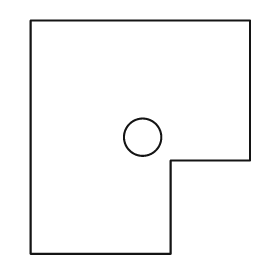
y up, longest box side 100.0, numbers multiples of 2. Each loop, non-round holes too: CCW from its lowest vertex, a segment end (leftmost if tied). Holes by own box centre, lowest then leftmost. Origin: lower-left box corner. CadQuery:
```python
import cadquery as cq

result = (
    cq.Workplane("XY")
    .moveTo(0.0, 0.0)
    .lineTo(60.0, 0.0)
    .lineTo(60.0, 40.0)
    .lineTo(94.0, 40.0)
    .lineTo(94.0, 100.0)
    .lineTo(0.0, 100.0)
    .close()
    .moveTo(48.0, 50.0)
    .circle(8.0)
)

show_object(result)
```